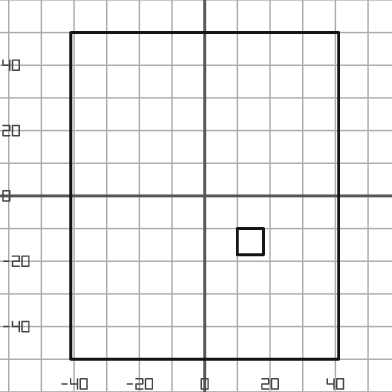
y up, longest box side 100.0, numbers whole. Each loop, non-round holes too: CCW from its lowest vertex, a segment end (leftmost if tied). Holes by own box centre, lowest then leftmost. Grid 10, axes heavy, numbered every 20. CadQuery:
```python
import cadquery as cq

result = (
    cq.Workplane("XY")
    .moveTo(-41.0, -50.0)
    .lineTo(41.0, -50.0)
    .lineTo(41.0, 50.0)
    .lineTo(-41.0, 50.0)
    .close()
    .moveTo(10.0, -18.0)
    .lineTo(18.0, -18.0)
    .lineTo(18.0, -10.0)
    .lineTo(10.0, -10.0)
    .close()
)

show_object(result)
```